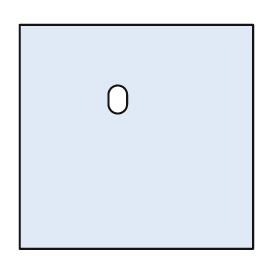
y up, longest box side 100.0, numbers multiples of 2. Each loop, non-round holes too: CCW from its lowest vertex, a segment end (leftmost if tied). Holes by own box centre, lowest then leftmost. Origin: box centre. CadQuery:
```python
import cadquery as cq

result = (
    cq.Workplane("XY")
    .moveTo(-50.0, -48.0)
    .lineTo(50.0, -48.0)
    .lineTo(50.0, 48.0)
    .lineTo(-50.0, 48.0)
    .close()
    .moveTo(-12.0, 14.0)
    .threePointArc((-8.0, 10.0), (-4.0, 14.0))
    .lineTo(-4.0, 18.0)
    .threePointArc((-8.0, 22.0), (-12.0, 18.0))
    .close()
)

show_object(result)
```